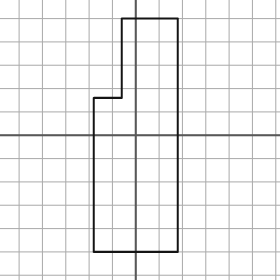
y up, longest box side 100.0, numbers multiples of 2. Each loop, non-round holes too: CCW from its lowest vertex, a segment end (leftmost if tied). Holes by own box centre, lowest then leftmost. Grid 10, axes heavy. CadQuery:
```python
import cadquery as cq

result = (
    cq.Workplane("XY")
    .moveTo(-18.0, -50.0)
    .lineTo(18.0, -50.0)
    .lineTo(18.0, 50.0)
    .lineTo(-6.0, 50.0)
    .lineTo(-6.0, 16.0)
    .lineTo(-18.0, 16.0)
    .close()
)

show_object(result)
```